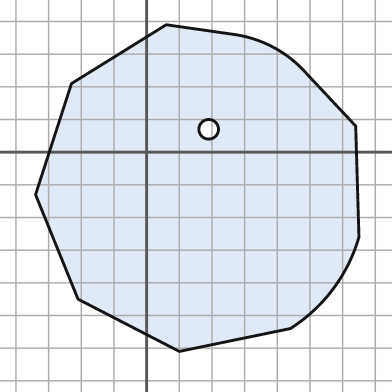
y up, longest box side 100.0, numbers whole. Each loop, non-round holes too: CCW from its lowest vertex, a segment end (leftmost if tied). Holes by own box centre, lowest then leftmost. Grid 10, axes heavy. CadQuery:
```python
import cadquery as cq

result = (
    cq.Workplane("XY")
    .moveTo(10.0, -61.0)
    .lineTo(44.0, -54.0)
    .threePointArc((57.0, -42.0), (65.0, -26.0))
    .lineTo(64.0, 8.0)
    .lineTo(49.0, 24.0)
    .threePointArc((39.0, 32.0), (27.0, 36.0))
    .lineTo(6.0, 39.0)
    .lineTo(-23.0, 21.0)
    .lineTo(-34.0, -13.0)
    .lineTo(-21.0, -45.0)
    .close()
    .moveTo(19.0, 7.0)
    .circle(3.0)
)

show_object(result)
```